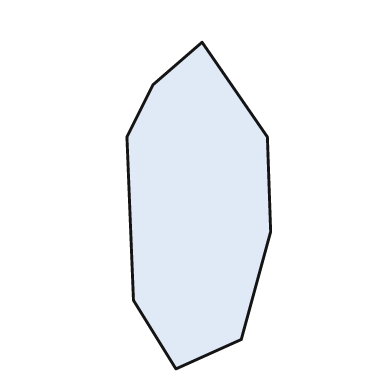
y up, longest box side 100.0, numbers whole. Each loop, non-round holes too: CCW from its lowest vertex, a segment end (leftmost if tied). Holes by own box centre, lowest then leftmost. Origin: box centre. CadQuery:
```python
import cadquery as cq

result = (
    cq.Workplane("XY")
    .moveTo(-7.0, -50.0)
    .lineTo(13.0, -41.0)
    .lineTo(22.0, -8.0)
    .lineTo(21.0, 21.0)
    .lineTo(1.0, 50.0)
    .lineTo(-14.0, 37.0)
    .lineTo(-22.0, 21.0)
    .lineTo(-20.0, -29.0)
    .close()
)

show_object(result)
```